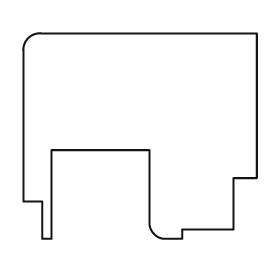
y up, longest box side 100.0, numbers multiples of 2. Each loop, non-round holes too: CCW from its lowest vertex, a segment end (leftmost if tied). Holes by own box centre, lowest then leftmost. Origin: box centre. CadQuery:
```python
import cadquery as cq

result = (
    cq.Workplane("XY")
    .moveTo(-42.0, -44.0)
    .lineTo(-38.0, -44.0)
    .lineTo(-38.0, -6.0)
    .lineTo(4.0, -6.0)
    .lineTo(4.0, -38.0)
    .threePointArc((6.0, -42.0), (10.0, -44.0))
    .lineTo(18.0, -44.0)
    .lineTo(18.0, -40.0)
    .lineTo(40.0, -40.0)
    .lineTo(40.0, -18.0)
    .lineTo(50.0, -18.0)
    .lineTo(50.0, 44.0)
    .lineTo(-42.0, 44.0)
    .threePointArc((-48.0, 42.0), (-50.0, 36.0))
    .lineTo(-50.0, -28.0)
    .lineTo(-42.0, -28.0)
    .close()
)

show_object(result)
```